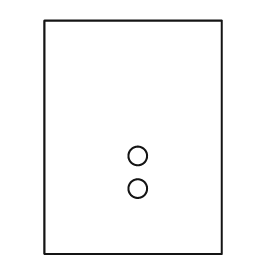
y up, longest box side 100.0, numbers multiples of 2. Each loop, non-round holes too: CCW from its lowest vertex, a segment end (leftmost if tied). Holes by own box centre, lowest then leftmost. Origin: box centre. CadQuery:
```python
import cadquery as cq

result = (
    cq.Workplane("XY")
    .moveTo(-38.0, -50.0)
    .lineTo(38.0, -50.0)
    .lineTo(38.0, 50.0)
    .lineTo(-38.0, 50.0)
    .close()
    .moveTo(2.0, -22.0)
    .circle(4.0)
    .moveTo(2.0, -8.0)
    .circle(4.0)
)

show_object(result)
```